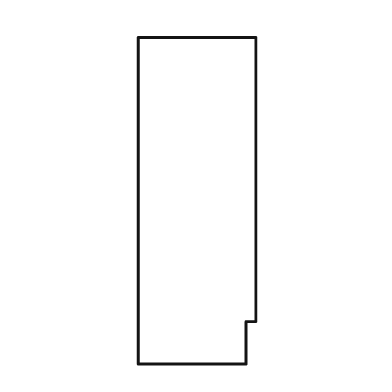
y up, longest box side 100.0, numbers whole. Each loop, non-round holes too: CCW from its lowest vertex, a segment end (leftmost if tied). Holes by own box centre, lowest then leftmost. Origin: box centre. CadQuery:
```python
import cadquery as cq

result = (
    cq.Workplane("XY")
    .moveTo(-18.0, -50.0)
    .lineTo(15.0, -50.0)
    .lineTo(15.0, -37.0)
    .lineTo(18.0, -37.0)
    .lineTo(18.0, 50.0)
    .lineTo(-18.0, 50.0)
    .close()
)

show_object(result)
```